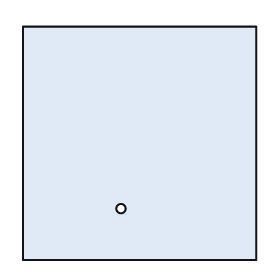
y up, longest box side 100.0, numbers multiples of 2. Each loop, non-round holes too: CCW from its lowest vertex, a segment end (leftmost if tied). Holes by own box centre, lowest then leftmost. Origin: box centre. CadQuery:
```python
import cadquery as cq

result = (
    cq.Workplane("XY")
    .moveTo(-50.0, -50.0)
    .lineTo(50.0, -50.0)
    .lineTo(50.0, 50.0)
    .lineTo(-50.0, 50.0)
    .close()
    .moveTo(-8.0, -28.0)
    .circle(2.0)
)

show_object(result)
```